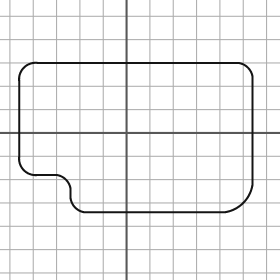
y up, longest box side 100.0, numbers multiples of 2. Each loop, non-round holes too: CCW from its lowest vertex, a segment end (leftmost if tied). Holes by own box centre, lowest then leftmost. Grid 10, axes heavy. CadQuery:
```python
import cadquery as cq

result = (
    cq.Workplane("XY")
    .moveTo(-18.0, -34.0)
    .lineTo(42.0, -34.0)
    .threePointArc((50.0, -30.0), (54.0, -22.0))
    .lineTo(54.0, 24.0)
    .threePointArc((52.0, 28.0), (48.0, 30.0))
    .lineTo(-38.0, 30.0)
    .threePointArc((-44.0, 28.0), (-46.0, 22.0))
    .lineTo(-46.0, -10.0)
    .threePointArc((-44.0, -16.0), (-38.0, -18.0))
    .lineTo(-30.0, -18.0)
    .threePointArc((-26.0, -20.0), (-24.0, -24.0))
    .lineTo(-24.0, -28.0)
    .threePointArc((-22.0, -32.0), (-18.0, -34.0))
    .close()
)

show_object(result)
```